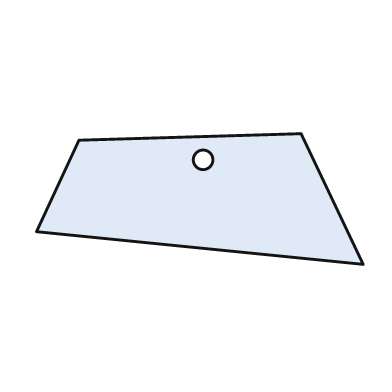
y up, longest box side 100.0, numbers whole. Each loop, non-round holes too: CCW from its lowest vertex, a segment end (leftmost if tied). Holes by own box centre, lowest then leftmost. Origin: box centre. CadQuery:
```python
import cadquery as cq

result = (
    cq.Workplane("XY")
    .moveTo(50.0, -20.0)
    .lineTo(31.0, 20.0)
    .lineTo(-37.0, 18.0)
    .lineTo(-50.0, -10.0)
    .close()
    .moveTo(1.0, 12.0)
    .circle(3.0)
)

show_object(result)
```